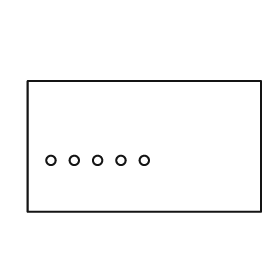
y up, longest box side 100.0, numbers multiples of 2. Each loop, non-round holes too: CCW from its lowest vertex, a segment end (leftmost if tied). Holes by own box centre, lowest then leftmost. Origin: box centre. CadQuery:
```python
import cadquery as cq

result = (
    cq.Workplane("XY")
    .moveTo(-50.0, -28.0)
    .lineTo(50.0, -28.0)
    .lineTo(50.0, 28.0)
    .lineTo(-50.0, 28.0)
    .close()
    .moveTo(-40.0, -6.0)
    .circle(2.0)
    .moveTo(-30.0, -6.0)
    .circle(2.0)
    .moveTo(-20.0, -6.0)
    .circle(2.0)
    .moveTo(-10.0, -6.0)
    .circle(2.0)
    .moveTo(0.0, -6.0)
    .circle(2.0)
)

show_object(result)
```